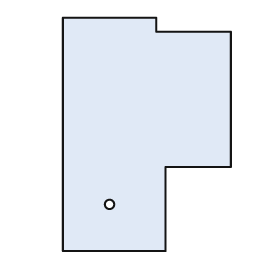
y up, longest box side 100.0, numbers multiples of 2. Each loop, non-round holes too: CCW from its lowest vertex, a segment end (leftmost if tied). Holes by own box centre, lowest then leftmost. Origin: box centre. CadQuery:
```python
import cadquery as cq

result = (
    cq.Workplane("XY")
    .moveTo(-36.0, -50.0)
    .lineTo(8.0, -50.0)
    .lineTo(8.0, -14.0)
    .lineTo(36.0, -14.0)
    .lineTo(36.0, 44.0)
    .lineTo(4.0, 44.0)
    .lineTo(4.0, 50.0)
    .lineTo(-36.0, 50.0)
    .close()
    .moveTo(-16.0, -30.0)
    .circle(2.0)
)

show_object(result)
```